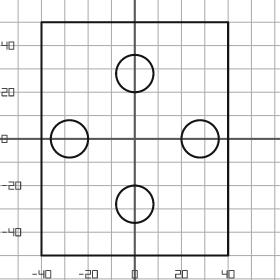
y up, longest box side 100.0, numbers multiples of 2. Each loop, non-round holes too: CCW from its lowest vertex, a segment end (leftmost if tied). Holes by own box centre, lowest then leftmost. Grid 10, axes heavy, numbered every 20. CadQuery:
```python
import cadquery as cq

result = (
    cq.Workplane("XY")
    .moveTo(-40.0, -50.0)
    .lineTo(40.0, -50.0)
    .lineTo(40.0, 50.0)
    .lineTo(-40.0, 50.0)
    .close()
    .moveTo(0.0, -28.0)
    .circle(8.0)
    .moveTo(-28.0, 0.0)
    .circle(8.0)
    .moveTo(28.0, 0.0)
    .circle(8.0)
    .moveTo(0.0, 28.0)
    .circle(8.0)
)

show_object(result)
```